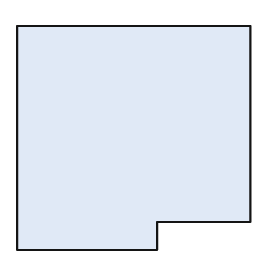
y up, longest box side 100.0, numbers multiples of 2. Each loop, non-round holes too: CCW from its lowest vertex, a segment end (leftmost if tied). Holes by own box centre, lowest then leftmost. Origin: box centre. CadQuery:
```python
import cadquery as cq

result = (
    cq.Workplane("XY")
    .moveTo(-50.0, -48.0)
    .lineTo(10.0, -48.0)
    .lineTo(10.0, -36.0)
    .lineTo(50.0, -36.0)
    .lineTo(50.0, 48.0)
    .lineTo(-50.0, 48.0)
    .close()
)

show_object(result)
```